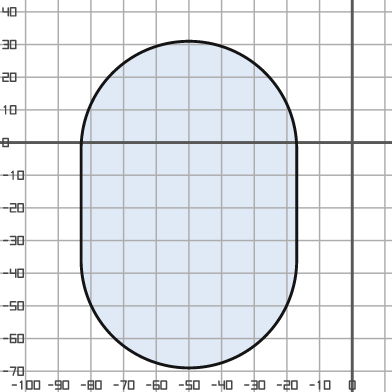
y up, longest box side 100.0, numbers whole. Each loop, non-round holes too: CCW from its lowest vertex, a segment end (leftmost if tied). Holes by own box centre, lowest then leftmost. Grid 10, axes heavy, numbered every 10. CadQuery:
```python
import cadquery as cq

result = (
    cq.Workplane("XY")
    .moveTo(-83.0, -36.0)
    .threePointArc((-50.0, -69.0), (-17.0, -36.0))
    .lineTo(-17.0, -2.0)
    .threePointArc((-50.0, 31.0), (-83.0, -2.0))
    .close()
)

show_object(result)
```